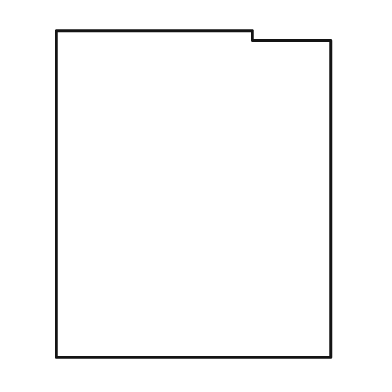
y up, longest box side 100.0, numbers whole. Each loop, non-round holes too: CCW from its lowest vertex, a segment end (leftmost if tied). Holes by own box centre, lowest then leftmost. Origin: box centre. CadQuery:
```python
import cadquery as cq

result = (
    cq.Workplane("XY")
    .moveTo(-42.0, -50.0)
    .lineTo(42.0, -50.0)
    .lineTo(42.0, 47.0)
    .lineTo(18.0, 47.0)
    .lineTo(18.0, 50.0)
    .lineTo(-42.0, 50.0)
    .close()
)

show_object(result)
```